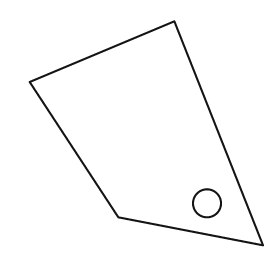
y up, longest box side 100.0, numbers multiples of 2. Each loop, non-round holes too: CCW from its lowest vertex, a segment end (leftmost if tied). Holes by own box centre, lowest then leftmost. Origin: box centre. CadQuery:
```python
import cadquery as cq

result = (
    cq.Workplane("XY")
    .moveTo(50.0, -48.0)
    .lineTo(12.0, 48.0)
    .lineTo(-50.0, 22.0)
    .lineTo(-12.0, -36.0)
    .close()
    .moveTo(26.0, -30.0)
    .circle(6.0)
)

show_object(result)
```